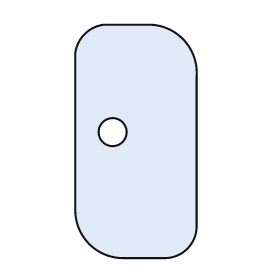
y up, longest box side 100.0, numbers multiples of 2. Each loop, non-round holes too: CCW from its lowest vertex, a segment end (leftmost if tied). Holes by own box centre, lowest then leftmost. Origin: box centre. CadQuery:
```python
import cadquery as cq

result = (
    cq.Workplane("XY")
    .moveTo(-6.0, -50.0)
    .lineTo(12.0, -50.0)
    .threePointArc((22.0, -46.0), (26.0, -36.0))
    .lineTo(26.0, 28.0)
    .threePointArc((20.0, 44.0), (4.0, 50.0))
    .lineTo(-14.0, 50.0)
    .threePointArc((-22.0, 46.0), (-26.0, 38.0))
    .lineTo(-26.0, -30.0)
    .threePointArc((-20.0, -44.0), (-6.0, -50.0))
    .close()
    .moveTo(-10.0, 4.0)
    .circle(6.0)
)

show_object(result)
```